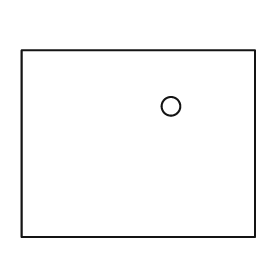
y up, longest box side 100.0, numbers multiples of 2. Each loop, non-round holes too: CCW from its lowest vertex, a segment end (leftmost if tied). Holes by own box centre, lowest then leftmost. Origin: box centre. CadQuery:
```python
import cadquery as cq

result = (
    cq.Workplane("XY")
    .moveTo(-50.0, -40.0)
    .lineTo(50.0, -40.0)
    .lineTo(50.0, 40.0)
    .lineTo(-50.0, 40.0)
    .close()
    .moveTo(14.0, 16.0)
    .circle(4.0)
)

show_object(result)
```